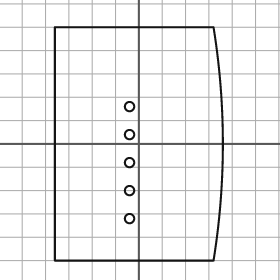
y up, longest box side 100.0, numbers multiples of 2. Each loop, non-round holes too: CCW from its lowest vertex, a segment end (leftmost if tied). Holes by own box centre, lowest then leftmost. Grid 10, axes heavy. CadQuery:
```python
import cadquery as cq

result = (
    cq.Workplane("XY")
    .moveTo(-36.0, -50.0)
    .lineTo(32.0, -50.0)
    .threePointArc((36.0, 0.0), (32.0, 50.0))
    .lineTo(-36.0, 50.0)
    .close()
    .moveTo(-4.0, -32.0)
    .circle(2.0)
    .moveTo(-4.0, -20.0)
    .circle(2.0)
    .moveTo(-4.0, -8.0)
    .circle(2.0)
    .moveTo(-4.0, 4.0)
    .circle(2.0)
    .moveTo(-4.0, 16.0)
    .circle(2.0)
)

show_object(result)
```